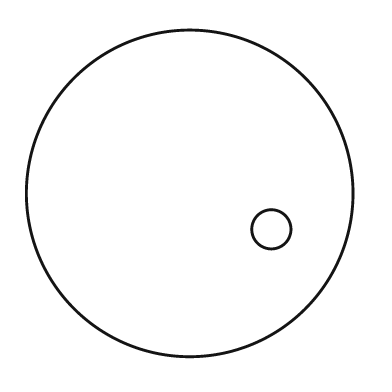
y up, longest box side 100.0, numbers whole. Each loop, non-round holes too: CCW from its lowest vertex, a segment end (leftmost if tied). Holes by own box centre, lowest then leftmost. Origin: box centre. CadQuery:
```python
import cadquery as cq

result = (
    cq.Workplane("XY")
    .moveTo(0.0, 0.0)
    .circle(50.0)
    .moveTo(25.0, -11.0)
    .circle(6.0)
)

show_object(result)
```